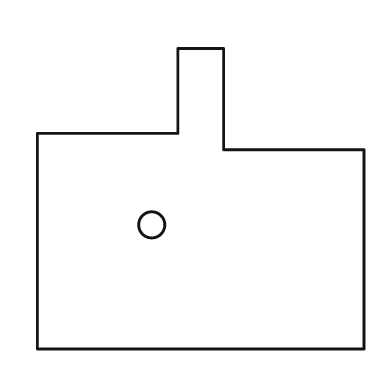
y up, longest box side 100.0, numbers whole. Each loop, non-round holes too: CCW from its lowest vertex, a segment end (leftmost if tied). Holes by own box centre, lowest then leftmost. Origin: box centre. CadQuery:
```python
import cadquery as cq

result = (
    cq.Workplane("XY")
    .moveTo(-50.0, -46.0)
    .lineTo(50.0, -46.0)
    .lineTo(50.0, 15.0)
    .lineTo(7.0, 15.0)
    .lineTo(7.0, 46.0)
    .lineTo(-7.0, 46.0)
    .lineTo(-7.0, 20.0)
    .lineTo(-50.0, 20.0)
    .close()
    .moveTo(-15.0, -8.0)
    .circle(4.0)
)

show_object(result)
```